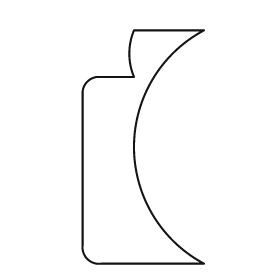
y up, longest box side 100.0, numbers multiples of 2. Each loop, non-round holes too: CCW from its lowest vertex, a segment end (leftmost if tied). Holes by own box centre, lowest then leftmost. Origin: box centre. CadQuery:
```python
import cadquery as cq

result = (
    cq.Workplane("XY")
    .moveTo(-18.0, -50.0)
    .lineTo(26.0, -50.0)
    .threePointArc((-4.0, 0.0), (26.0, 50.0))
    .lineTo(-4.0, 50.0)
    .threePointArc((-6.0, 40.0), (-4.0, 30.0))
    .lineTo(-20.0, 30.0)
    .threePointArc((-24.0, 28.0), (-26.0, 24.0))
    .lineTo(-26.0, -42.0)
    .threePointArc((-24.0, -48.0), (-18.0, -50.0))
    .close()
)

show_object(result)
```